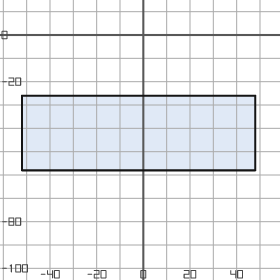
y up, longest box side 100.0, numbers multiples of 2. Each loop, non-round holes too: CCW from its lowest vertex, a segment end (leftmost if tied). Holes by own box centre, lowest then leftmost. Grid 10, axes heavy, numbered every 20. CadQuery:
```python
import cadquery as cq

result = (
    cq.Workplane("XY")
    .moveTo(-52.0, -58.0)
    .lineTo(48.0, -58.0)
    .lineTo(48.0, -26.0)
    .lineTo(-52.0, -26.0)
    .close()
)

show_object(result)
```